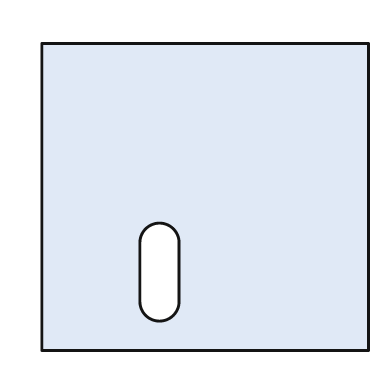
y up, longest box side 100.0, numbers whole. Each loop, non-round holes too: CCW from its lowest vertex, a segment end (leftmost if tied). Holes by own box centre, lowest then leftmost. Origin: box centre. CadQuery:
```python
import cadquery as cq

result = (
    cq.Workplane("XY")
    .moveTo(-50.0, -47.0)
    .lineTo(50.0, -47.0)
    .lineTo(50.0, 47.0)
    .lineTo(-50.0, 47.0)
    .close()
    .moveTo(-20.0, -32.0)
    .threePointArc((-14.0, -38.0), (-8.0, -32.0))
    .lineTo(-8.0, -14.0)
    .threePointArc((-14.0, -8.0), (-20.0, -14.0))
    .close()
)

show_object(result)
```